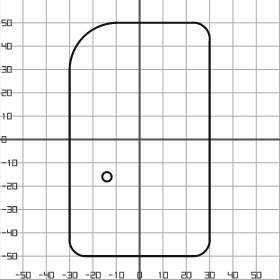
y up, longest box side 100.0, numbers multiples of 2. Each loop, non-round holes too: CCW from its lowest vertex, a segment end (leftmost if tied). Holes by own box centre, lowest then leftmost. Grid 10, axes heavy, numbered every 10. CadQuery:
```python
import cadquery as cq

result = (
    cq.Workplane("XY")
    .moveTo(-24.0, -50.0)
    .lineTo(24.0, -50.0)
    .threePointArc((28.0, -48.0), (30.0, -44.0))
    .lineTo(30.0, 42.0)
    .threePointArc((28.0, 48.0), (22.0, 50.0))
    .lineTo(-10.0, 50.0)
    .threePointArc((-24.0, 44.0), (-30.0, 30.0))
    .lineTo(-30.0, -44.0)
    .threePointArc((-28.0, -48.0), (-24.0, -50.0))
    .close()
    .moveTo(-14.0, -16.0)
    .circle(2.0)
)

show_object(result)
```